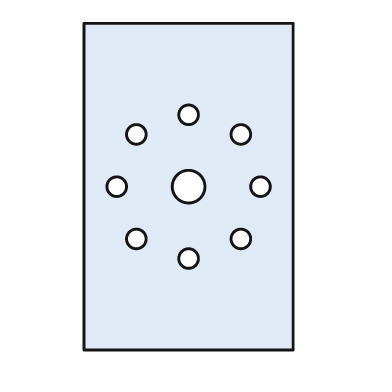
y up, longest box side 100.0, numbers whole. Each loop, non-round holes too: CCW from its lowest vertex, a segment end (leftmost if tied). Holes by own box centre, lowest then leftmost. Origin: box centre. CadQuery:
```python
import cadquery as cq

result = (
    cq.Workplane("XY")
    .moveTo(-32.0, -50.0)
    .lineTo(32.0, -50.0)
    .lineTo(32.0, 50.0)
    .lineTo(-32.0, 50.0)
    .close()
    .moveTo(0.0, -22.0)
    .circle(3.0)
    .moveTo(-16.0, -16.0)
    .circle(3.0)
    .moveTo(16.0, -16.0)
    .circle(3.0)
    .moveTo(-22.0, 0.0)
    .circle(3.0)
    .moveTo(0.0, 0.0)
    .circle(5.0)
    .moveTo(22.0, 0.0)
    .circle(3.0)
    .moveTo(-16.0, 16.0)
    .circle(3.0)
    .moveTo(16.0, 16.0)
    .circle(3.0)
    .moveTo(0.0, 22.0)
    .circle(3.0)
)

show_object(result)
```